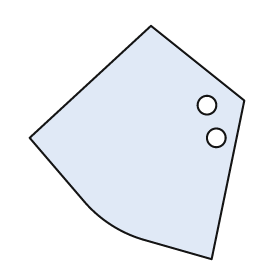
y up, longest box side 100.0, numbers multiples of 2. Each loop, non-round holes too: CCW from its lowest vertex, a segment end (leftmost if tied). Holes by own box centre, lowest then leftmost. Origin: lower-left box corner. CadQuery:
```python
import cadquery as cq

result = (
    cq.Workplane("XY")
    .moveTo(78.0, 0.0)
    .lineTo(92.0, 68.0)
    .lineTo(52.0, 100.0)
    .lineTo(0.0, 52.0)
    .lineTo(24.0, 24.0)
    .threePointArc((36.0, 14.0), (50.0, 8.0))
    .close()
    .moveTo(80.0, 52.0)
    .circle(4.0)
    .moveTo(76.0, 66.0)
    .circle(4.0)
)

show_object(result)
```